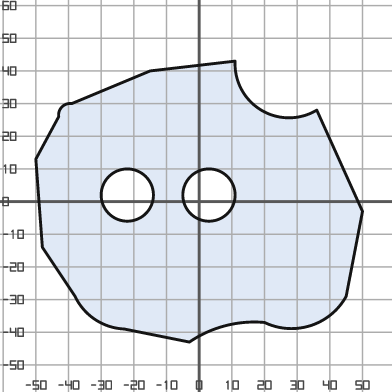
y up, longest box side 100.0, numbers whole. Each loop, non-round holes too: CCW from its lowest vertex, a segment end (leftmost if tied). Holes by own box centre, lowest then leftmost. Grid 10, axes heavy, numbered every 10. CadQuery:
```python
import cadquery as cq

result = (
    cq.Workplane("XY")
    .moveTo(-3.0, -43.0)
    .threePointArc((8.0, -38.0), (20.0, -37.0))
    .threePointArc((34.0, -38.0), (45.0, -29.0))
    .lineTo(50.0, -3.0)
    .lineTo(36.0, 28.0)
    .threePointArc((19.0, 28.0), (11.0, 43.0))
    .lineTo(-15.0, 40.0)
    .lineTo(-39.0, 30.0)
    .threePointArc((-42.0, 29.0), (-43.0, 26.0))
    .lineTo(-50.0, 13.0)
    .lineTo(-48.0, -14.0)
    .lineTo(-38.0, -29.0)
    .threePointArc((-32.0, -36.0), (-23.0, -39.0))
    .close()
    .moveTo(-22.0, 2.0)
    .circle(8.0)
    .moveTo(3.0, 2.0)
    .circle(8.0)
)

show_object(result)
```